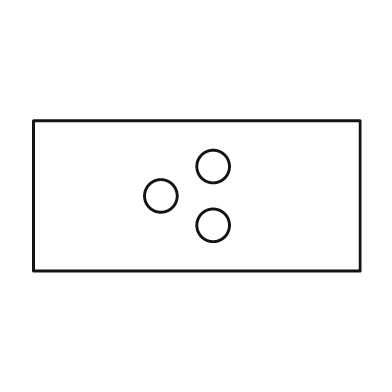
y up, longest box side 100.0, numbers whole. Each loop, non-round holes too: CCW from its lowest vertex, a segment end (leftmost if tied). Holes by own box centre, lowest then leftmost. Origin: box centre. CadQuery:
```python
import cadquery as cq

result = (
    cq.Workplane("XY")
    .moveTo(-50.0, -23.0)
    .lineTo(50.0, -23.0)
    .lineTo(50.0, 23.0)
    .lineTo(-50.0, 23.0)
    .close()
    .moveTo(5.0, -9.0)
    .circle(5.0)
    .moveTo(-11.0, 0.0)
    .circle(5.0)
    .moveTo(5.0, 9.0)
    .circle(5.0)
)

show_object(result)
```